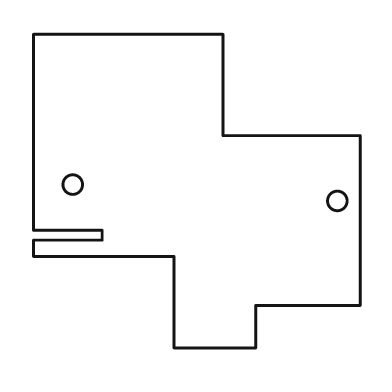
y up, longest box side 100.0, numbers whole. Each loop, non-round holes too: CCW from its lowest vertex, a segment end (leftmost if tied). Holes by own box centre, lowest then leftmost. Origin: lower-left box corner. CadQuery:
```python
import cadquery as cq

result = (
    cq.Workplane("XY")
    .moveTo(43.0, 0.0)
    .lineTo(68.0, 0.0)
    .lineTo(68.0, 13.0)
    .lineTo(100.0, 13.0)
    .lineTo(100.0, 65.0)
    .lineTo(58.0, 65.0)
    .lineTo(58.0, 96.0)
    .lineTo(0.0, 96.0)
    .lineTo(0.0, 36.0)
    .lineTo(21.0, 36.0)
    .lineTo(21.0, 33.0)
    .lineTo(0.0, 33.0)
    .lineTo(0.0, 28.0)
    .lineTo(43.0, 28.0)
    .close()
    .moveTo(93.0, 45.0)
    .circle(3.0)
    .moveTo(12.0, 50.0)
    .circle(3.0)
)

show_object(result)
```